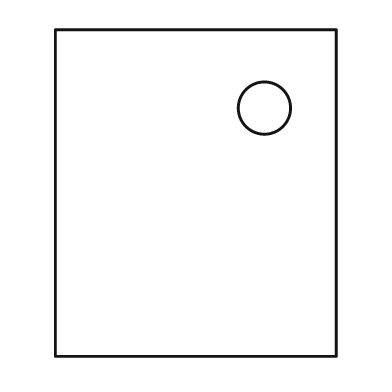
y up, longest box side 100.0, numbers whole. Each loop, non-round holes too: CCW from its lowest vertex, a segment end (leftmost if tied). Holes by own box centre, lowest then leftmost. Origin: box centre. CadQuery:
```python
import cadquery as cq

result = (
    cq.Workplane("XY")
    .moveTo(-43.0, -50.0)
    .lineTo(43.0, -50.0)
    .lineTo(43.0, 50.0)
    .lineTo(-43.0, 50.0)
    .close()
    .moveTo(21.0, 26.0)
    .circle(8.0)
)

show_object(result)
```